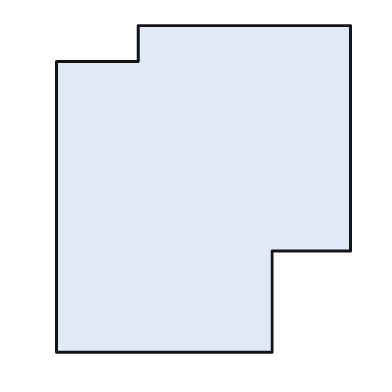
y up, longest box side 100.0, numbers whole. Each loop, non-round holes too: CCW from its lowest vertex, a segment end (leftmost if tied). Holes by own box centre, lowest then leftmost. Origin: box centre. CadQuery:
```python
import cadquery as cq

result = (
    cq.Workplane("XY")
    .moveTo(-45.0, -50.0)
    .lineTo(21.0, -50.0)
    .lineTo(21.0, -19.0)
    .lineTo(45.0, -19.0)
    .lineTo(45.0, 50.0)
    .lineTo(-20.0, 50.0)
    .lineTo(-20.0, 39.0)
    .lineTo(-45.0, 39.0)
    .close()
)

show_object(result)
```